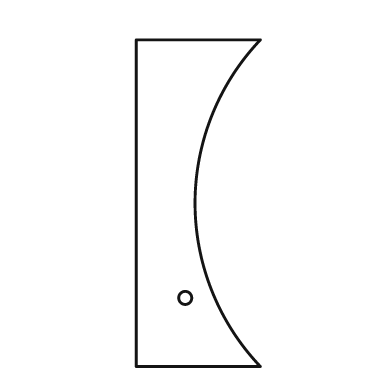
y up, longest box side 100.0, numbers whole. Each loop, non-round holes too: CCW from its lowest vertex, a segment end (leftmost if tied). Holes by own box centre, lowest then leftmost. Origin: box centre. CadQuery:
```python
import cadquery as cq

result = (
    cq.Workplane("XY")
    .moveTo(-19.0, -50.0)
    .lineTo(19.0, -50.0)
    .threePointArc((-1.0, 0.0), (19.0, 50.0))
    .lineTo(-19.0, 50.0)
    .close()
    .moveTo(-4.0, -29.0)
    .circle(2.0)
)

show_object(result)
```